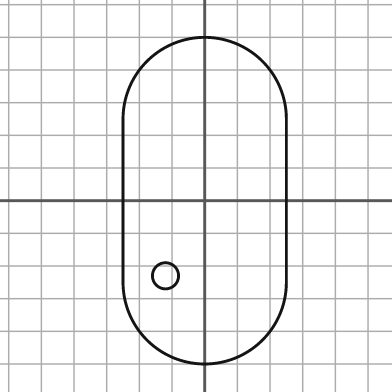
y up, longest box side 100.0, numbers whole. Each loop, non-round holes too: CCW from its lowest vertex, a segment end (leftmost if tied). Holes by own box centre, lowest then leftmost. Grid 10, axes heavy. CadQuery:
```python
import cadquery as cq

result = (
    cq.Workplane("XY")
    .moveTo(-25.0, -25.0)
    .threePointArc((0.0, -50.0), (25.0, -25.0))
    .lineTo(25.0, 25.0)
    .threePointArc((0.0, 50.0), (-25.0, 25.0))
    .close()
    .moveTo(-12.0, -23.0)
    .circle(4.0)
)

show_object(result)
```